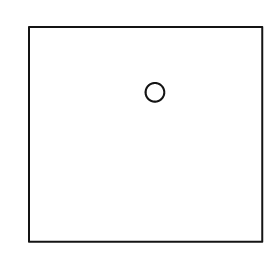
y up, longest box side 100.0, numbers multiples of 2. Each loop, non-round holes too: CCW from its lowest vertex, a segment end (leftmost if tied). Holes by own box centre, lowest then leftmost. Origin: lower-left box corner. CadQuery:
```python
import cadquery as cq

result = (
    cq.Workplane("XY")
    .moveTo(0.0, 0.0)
    .lineTo(100.0, 0.0)
    .lineTo(100.0, 92.0)
    .lineTo(0.0, 92.0)
    .close()
    .moveTo(54.0, 64.0)
    .circle(4.0)
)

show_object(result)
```